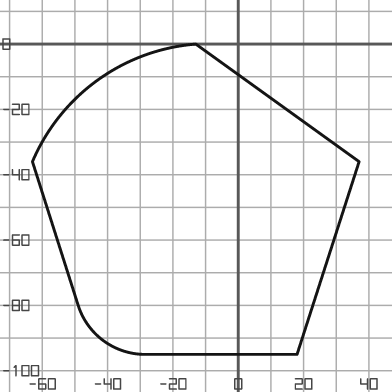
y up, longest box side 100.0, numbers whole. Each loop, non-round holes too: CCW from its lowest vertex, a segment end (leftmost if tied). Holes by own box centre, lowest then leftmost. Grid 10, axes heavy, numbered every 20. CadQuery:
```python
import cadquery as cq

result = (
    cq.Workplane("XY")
    .moveTo(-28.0, -95.0)
    .lineTo(18.0, -95.0)
    .lineTo(37.0, -36.0)
    .lineTo(-13.0, 0.0)
    .threePointArc((-43.0, -11.0), (-63.0, -36.0))
    .lineTo(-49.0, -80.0)
    .threePointArc((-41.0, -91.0), (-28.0, -95.0))
    .close()
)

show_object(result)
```